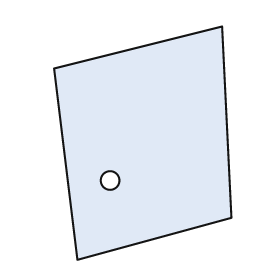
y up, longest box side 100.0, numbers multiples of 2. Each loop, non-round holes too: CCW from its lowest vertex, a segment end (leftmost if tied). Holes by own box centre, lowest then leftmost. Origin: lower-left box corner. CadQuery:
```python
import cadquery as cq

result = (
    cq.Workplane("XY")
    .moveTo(10.0, 0.0)
    .lineTo(76.0, 18.0)
    .lineTo(72.0, 100.0)
    .lineTo(0.0, 82.0)
    .close()
    .moveTo(24.0, 34.0)
    .circle(4.0)
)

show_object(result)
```